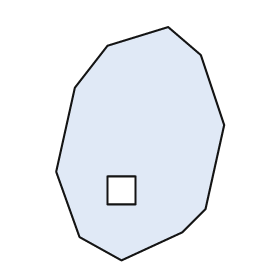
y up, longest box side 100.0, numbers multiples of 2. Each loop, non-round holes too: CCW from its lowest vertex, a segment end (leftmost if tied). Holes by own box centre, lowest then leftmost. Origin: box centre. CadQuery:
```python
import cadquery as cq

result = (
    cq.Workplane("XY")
    .moveTo(-8.0, -50.0)
    .lineTo(18.0, -38.0)
    .lineTo(28.0, -28.0)
    .lineTo(36.0, 8.0)
    .lineTo(26.0, 38.0)
    .lineTo(12.0, 50.0)
    .lineTo(-14.0, 42.0)
    .lineTo(-28.0, 24.0)
    .lineTo(-36.0, -12.0)
    .lineTo(-26.0, -40.0)
    .close()
    .moveTo(-14.0, -26.0)
    .lineTo(-2.0, -26.0)
    .lineTo(-2.0, -14.0)
    .lineTo(-14.0, -14.0)
    .close()
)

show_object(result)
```